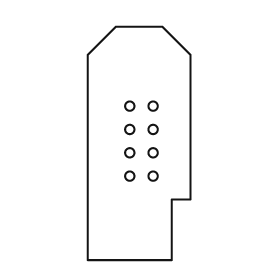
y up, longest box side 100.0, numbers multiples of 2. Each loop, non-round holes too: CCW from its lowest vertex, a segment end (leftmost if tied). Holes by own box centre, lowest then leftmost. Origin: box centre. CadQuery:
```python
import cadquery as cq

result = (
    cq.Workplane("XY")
    .moveTo(-22.0, -50.0)
    .lineTo(14.0, -50.0)
    .lineTo(14.0, -24.0)
    .lineTo(22.0, -24.0)
    .lineTo(22.0, 38.0)
    .lineTo(10.0, 50.0)
    .lineTo(-10.0, 50.0)
    .lineTo(-22.0, 38.0)
    .close()
    .moveTo(-4.0, -14.0)
    .circle(2.0)
    .moveTo(6.0, -14.0)
    .circle(2.0)
    .moveTo(-4.0, -4.0)
    .circle(2.0)
    .moveTo(6.0, -4.0)
    .circle(2.0)
    .moveTo(-4.0, 6.0)
    .circle(2.0)
    .moveTo(6.0, 6.0)
    .circle(2.0)
    .moveTo(-4.0, 16.0)
    .circle(2.0)
    .moveTo(6.0, 16.0)
    .circle(2.0)
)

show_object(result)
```